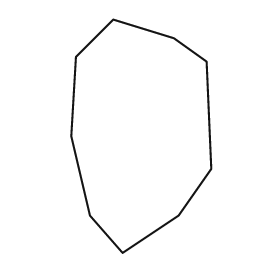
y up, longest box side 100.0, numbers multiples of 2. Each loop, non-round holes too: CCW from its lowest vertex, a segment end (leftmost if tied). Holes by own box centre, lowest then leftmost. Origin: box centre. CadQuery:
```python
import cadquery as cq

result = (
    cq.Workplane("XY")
    .moveTo(-8.0, -50.0)
    .lineTo(16.0, -34.0)
    .lineTo(30.0, -14.0)
    .lineTo(28.0, 32.0)
    .lineTo(14.0, 42.0)
    .lineTo(-12.0, 50.0)
    .lineTo(-28.0, 34.0)
    .lineTo(-30.0, 0.0)
    .lineTo(-22.0, -34.0)
    .close()
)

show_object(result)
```